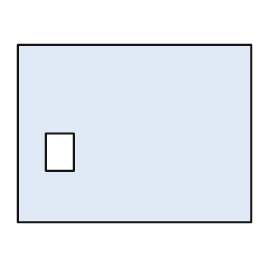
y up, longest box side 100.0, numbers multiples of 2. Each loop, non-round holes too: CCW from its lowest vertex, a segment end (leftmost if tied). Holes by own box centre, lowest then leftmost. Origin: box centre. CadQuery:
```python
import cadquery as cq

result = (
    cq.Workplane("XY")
    .moveTo(-50.0, -38.0)
    .lineTo(50.0, -38.0)
    .lineTo(50.0, 38.0)
    .lineTo(-50.0, 38.0)
    .close()
    .moveTo(-38.0, -16.0)
    .lineTo(-26.0, -16.0)
    .lineTo(-26.0, 0.0)
    .lineTo(-38.0, 0.0)
    .close()
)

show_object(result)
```